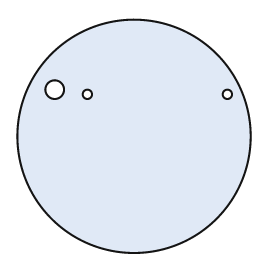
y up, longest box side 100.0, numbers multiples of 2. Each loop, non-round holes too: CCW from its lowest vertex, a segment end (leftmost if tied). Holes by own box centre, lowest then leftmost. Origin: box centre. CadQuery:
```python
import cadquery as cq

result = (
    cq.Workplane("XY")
    .moveTo(0.0, 0.0)
    .circle(50.0)
    .moveTo(-20.0, 18.0)
    .circle(2.0)
    .moveTo(40.0, 18.0)
    .circle(2.0)
    .moveTo(-34.0, 20.0)
    .circle(4.0)
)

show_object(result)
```